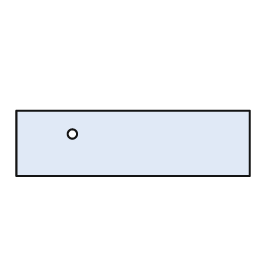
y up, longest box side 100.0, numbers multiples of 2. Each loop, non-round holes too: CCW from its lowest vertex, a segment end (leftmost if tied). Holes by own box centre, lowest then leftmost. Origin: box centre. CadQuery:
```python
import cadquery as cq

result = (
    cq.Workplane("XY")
    .moveTo(-50.0, -14.0)
    .lineTo(50.0, -14.0)
    .lineTo(50.0, 14.0)
    .lineTo(-50.0, 14.0)
    .close()
    .moveTo(-26.0, 4.0)
    .circle(2.0)
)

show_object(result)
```